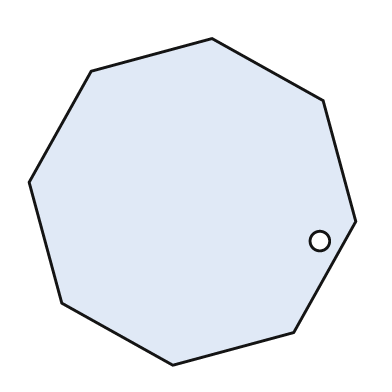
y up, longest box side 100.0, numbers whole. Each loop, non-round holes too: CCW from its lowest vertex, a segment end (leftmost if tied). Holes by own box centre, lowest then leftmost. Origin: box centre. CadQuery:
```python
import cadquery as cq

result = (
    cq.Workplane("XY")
    .moveTo(-6.0, -50.0)
    .lineTo(31.0, -40.0)
    .lineTo(50.0, -6.0)
    .lineTo(40.0, 31.0)
    .lineTo(6.0, 50.0)
    .lineTo(-31.0, 40.0)
    .lineTo(-50.0, 6.0)
    .lineTo(-40.0, -31.0)
    .close()
    .moveTo(39.0, -12.0)
    .circle(3.0)
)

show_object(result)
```